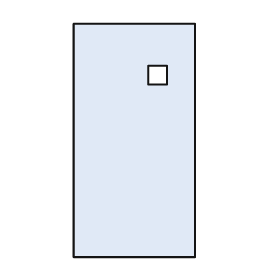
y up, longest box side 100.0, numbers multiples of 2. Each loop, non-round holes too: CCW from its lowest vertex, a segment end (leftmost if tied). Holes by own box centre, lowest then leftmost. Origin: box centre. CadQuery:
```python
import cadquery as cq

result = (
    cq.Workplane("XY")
    .moveTo(-26.0, -50.0)
    .lineTo(26.0, -50.0)
    .lineTo(26.0, 50.0)
    .lineTo(-26.0, 50.0)
    .close()
    .moveTo(6.0, 24.0)
    .lineTo(14.0, 24.0)
    .lineTo(14.0, 32.0)
    .lineTo(6.0, 32.0)
    .close()
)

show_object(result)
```